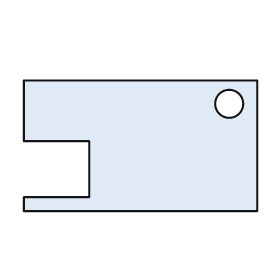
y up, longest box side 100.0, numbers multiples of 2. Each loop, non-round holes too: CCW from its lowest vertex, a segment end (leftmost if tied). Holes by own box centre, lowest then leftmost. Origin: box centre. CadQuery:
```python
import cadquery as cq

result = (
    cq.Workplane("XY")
    .moveTo(-50.0, -28.0)
    .lineTo(50.0, -28.0)
    .lineTo(50.0, 28.0)
    .lineTo(-50.0, 28.0)
    .lineTo(-50.0, 2.0)
    .lineTo(-22.0, 2.0)
    .lineTo(-22.0, -22.0)
    .lineTo(-50.0, -22.0)
    .close()
    .moveTo(38.0, 18.0)
    .circle(6.0)
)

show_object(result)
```